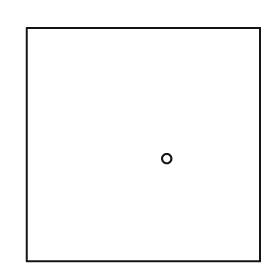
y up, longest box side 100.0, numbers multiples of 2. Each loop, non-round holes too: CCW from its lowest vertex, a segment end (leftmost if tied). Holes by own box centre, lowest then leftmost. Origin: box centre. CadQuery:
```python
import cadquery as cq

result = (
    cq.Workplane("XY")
    .moveTo(-50.0, -50.0)
    .lineTo(50.0, -50.0)
    .lineTo(50.0, 50.0)
    .lineTo(-50.0, 50.0)
    .close()
    .moveTo(10.0, -6.0)
    .circle(2.0)
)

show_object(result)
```